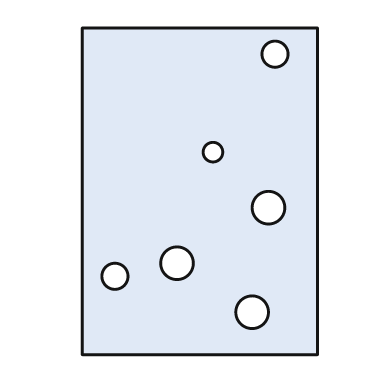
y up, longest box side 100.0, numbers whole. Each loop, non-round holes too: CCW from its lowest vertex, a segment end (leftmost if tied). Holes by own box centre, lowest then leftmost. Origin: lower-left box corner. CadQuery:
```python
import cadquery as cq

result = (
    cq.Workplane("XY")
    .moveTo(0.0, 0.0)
    .lineTo(72.0, 0.0)
    .lineTo(72.0, 100.0)
    .lineTo(0.0, 100.0)
    .close()
    .moveTo(52.0, 13.0)
    .circle(5.0)
    .moveTo(10.0, 24.0)
    .circle(4.0)
    .moveTo(29.0, 28.0)
    .circle(5.0)
    .moveTo(57.0, 45.0)
    .circle(5.0)
    .moveTo(40.0, 62.0)
    .circle(3.0)
    .moveTo(59.0, 92.0)
    .circle(4.0)
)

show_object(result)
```